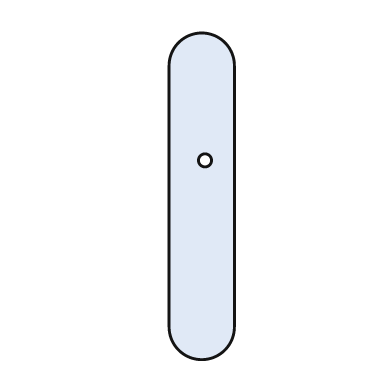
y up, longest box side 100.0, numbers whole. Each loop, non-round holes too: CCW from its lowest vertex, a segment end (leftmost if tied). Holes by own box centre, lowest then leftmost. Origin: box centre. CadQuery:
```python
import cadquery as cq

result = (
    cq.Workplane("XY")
    .moveTo(-10.0, -40.0)
    .threePointArc((0.0, -50.0), (10.0, -40.0))
    .lineTo(10.0, 40.0)
    .threePointArc((0.0, 50.0), (-10.0, 40.0))
    .close()
    .moveTo(1.0, 11.0)
    .circle(2.0)
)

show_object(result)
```